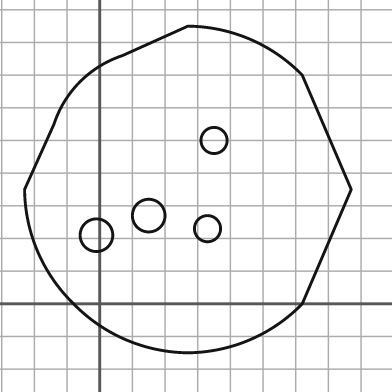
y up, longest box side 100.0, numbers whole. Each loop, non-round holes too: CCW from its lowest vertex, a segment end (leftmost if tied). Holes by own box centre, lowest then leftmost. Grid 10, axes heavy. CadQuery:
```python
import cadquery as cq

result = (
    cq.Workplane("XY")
    .moveTo(27.0, -15.0)
    .threePointArc((46.0, -11.0), (62.0, 0.0))
    .lineTo(77.0, 35.0)
    .lineTo(62.0, 70.0)
    .threePointArc((46.0, 81.0), (27.0, 85.0))
    .lineTo(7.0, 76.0)
    .threePointArc((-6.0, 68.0), (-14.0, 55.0))
    .lineTo(-23.0, 35.0)
    .threePointArc((-19.0, 16.0), (-8.0, 0.0))
    .threePointArc((8.0, -11.0), (27.0, -15.0))
    .close()
    .moveTo(-1.0, 21.0)
    .circle(5.0)
    .moveTo(33.0, 23.0)
    .circle(4.0)
    .moveTo(15.0, 27.0)
    .circle(5.0)
    .moveTo(35.0, 50.0)
    .circle(4.0)
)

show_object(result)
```